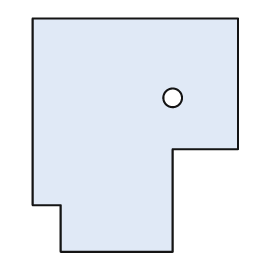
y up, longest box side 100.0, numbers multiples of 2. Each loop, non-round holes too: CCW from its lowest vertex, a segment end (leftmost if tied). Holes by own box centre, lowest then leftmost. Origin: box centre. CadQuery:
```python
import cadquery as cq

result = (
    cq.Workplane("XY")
    .moveTo(-32.0, -50.0)
    .lineTo(16.0, -50.0)
    .lineTo(16.0, -6.0)
    .lineTo(44.0, -6.0)
    .lineTo(44.0, 50.0)
    .lineTo(-44.0, 50.0)
    .lineTo(-44.0, -30.0)
    .lineTo(-32.0, -30.0)
    .close()
    .moveTo(16.0, 16.0)
    .circle(4.0)
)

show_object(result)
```